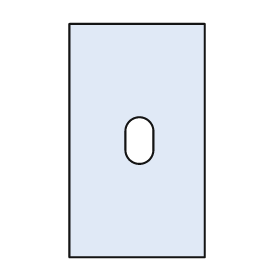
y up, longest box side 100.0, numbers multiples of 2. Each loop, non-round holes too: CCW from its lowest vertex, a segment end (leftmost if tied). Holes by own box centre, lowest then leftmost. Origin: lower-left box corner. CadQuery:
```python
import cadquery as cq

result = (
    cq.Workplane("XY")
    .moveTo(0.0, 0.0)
    .lineTo(58.0, 0.0)
    .lineTo(58.0, 100.0)
    .lineTo(0.0, 100.0)
    .close()
    .moveTo(24.0, 46.0)
    .threePointArc((30.0, 40.0), (36.0, 46.0))
    .lineTo(36.0, 54.0)
    .threePointArc((30.0, 60.0), (24.0, 54.0))
    .close()
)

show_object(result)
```